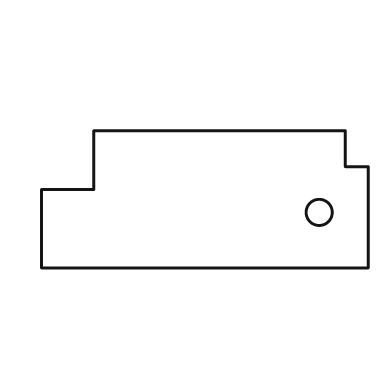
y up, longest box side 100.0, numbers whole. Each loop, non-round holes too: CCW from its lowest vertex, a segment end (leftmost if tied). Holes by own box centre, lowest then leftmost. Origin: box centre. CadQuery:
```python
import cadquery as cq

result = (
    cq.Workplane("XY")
    .moveTo(-50.0, -21.0)
    .lineTo(50.0, -21.0)
    .lineTo(50.0, 10.0)
    .lineTo(43.0, 10.0)
    .lineTo(43.0, 21.0)
    .lineTo(-34.0, 21.0)
    .lineTo(-34.0, 3.0)
    .lineTo(-50.0, 3.0)
    .close()
    .moveTo(35.0, -4.0)
    .circle(4.0)
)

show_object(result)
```